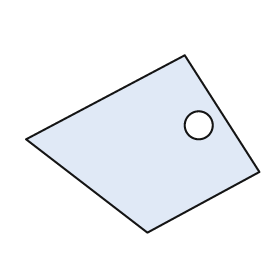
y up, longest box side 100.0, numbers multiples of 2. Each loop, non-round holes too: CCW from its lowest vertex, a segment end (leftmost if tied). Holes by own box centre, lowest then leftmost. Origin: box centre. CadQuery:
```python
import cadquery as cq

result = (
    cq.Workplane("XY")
    .moveTo(2.0, -38.0)
    .lineTo(50.0, -12.0)
    .lineTo(18.0, 38.0)
    .lineTo(-50.0, 2.0)
    .close()
    .moveTo(24.0, 8.0)
    .circle(6.0)
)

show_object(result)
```